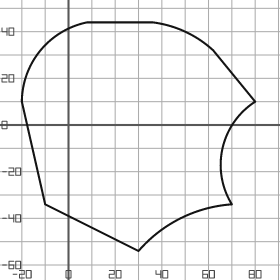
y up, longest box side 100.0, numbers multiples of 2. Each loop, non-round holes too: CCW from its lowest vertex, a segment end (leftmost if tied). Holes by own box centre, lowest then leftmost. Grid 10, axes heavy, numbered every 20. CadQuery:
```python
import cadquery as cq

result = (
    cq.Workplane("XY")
    .moveTo(30.0, -54.0)
    .threePointArc((48.0, -40.0), (70.0, -34.0))
    .threePointArc((66.0, -10.0), (80.0, 10.0))
    .lineTo(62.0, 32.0)
    .threePointArc((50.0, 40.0), (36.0, 44.0))
    .lineTo(8.0, 44.0)
    .threePointArc((-12.0, 32.0), (-20.0, 10.0))
    .lineTo(-10.0, -34.0)
    .close()
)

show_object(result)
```